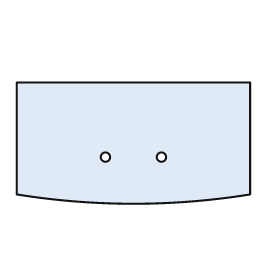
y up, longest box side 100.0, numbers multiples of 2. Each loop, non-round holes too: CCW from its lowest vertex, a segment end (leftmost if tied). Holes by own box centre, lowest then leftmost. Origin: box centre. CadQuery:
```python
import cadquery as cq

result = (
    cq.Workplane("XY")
    .moveTo(-50.0, -22.0)
    .threePointArc((0.0, -26.0), (50.0, -22.0))
    .lineTo(50.0, 26.0)
    .lineTo(-50.0, 26.0)
    .close()
    .moveTo(-12.0, -6.0)
    .circle(2.0)
    .moveTo(12.0, -6.0)
    .circle(2.0)
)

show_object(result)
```